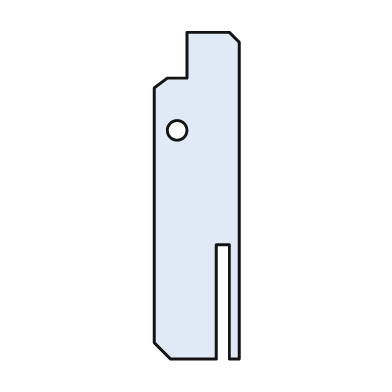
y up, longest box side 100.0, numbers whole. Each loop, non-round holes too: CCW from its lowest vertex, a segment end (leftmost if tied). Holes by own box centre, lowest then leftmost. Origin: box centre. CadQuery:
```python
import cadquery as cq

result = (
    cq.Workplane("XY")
    .moveTo(-8.0, -50.0)
    .lineTo(6.0, -50.0)
    .lineTo(6.0, -15.0)
    .lineTo(10.0, -15.0)
    .lineTo(10.0, -50.0)
    .lineTo(13.0, -50.0)
    .lineTo(13.0, 47.0)
    .lineTo(10.0, 50.0)
    .lineTo(-3.0, 50.0)
    .lineTo(-3.0, 36.0)
    .lineTo(-9.0, 36.0)
    .lineTo(-13.0, 33.0)
    .lineTo(-13.0, -45.0)
    .close()
    .moveTo(-6.0, 20.0)
    .circle(3.0)
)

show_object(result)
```